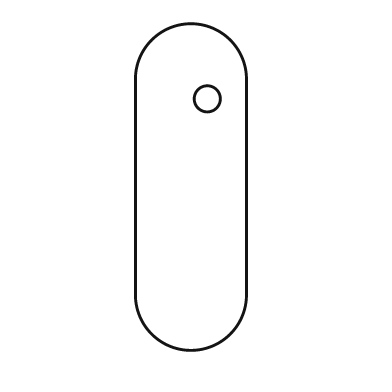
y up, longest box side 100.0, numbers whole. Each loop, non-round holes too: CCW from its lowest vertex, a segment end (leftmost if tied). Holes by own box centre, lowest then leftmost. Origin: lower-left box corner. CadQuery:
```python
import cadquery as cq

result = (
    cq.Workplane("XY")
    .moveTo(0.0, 17.0)
    .threePointArc((17.0, 0.0), (34.0, 17.0))
    .lineTo(34.0, 83.0)
    .threePointArc((17.0, 100.0), (0.0, 83.0))
    .close()
    .moveTo(22.0, 77.0)
    .circle(4.0)
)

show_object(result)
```